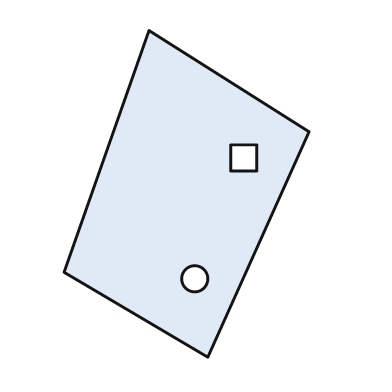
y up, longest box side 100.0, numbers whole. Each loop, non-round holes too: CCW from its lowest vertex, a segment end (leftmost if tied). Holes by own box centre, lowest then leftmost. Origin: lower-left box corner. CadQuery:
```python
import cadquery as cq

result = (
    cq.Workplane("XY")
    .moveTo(44.0, 0.0)
    .lineTo(75.0, 69.0)
    .lineTo(26.0, 100.0)
    .lineTo(0.0, 26.0)
    .close()
    .moveTo(40.0, 24.0)
    .circle(4.0)
    .moveTo(51.0, 57.0)
    .lineTo(59.0, 57.0)
    .lineTo(59.0, 65.0)
    .lineTo(51.0, 65.0)
    .close()
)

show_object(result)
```